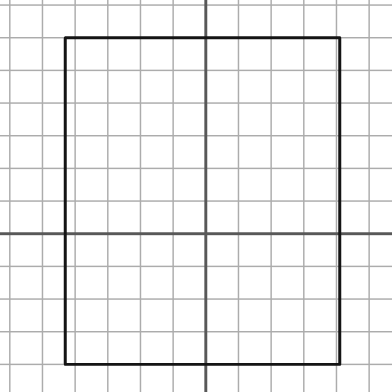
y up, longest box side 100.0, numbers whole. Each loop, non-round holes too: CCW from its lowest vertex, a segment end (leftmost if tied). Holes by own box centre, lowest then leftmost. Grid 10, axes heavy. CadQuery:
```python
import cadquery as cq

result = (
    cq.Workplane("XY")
    .moveTo(-43.0, -40.0)
    .lineTo(41.0, -40.0)
    .lineTo(41.0, 60.0)
    .lineTo(-43.0, 60.0)
    .close()
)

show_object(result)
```